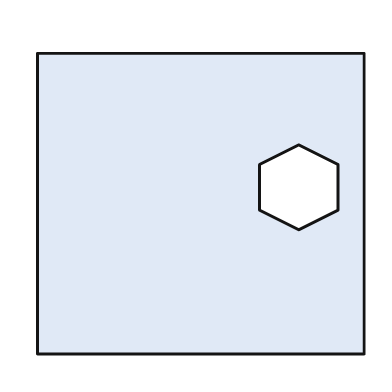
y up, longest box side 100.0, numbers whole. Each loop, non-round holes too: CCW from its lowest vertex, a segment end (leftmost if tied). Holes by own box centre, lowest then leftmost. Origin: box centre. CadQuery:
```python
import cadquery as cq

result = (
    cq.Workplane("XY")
    .moveTo(-50.0, -46.0)
    .lineTo(50.0, -46.0)
    .lineTo(50.0, 46.0)
    .lineTo(-50.0, 46.0)
    .close()
    .moveTo(30.0, -8.0)
    .lineTo(42.0, -2.0)
    .lineTo(42.0, 12.0)
    .lineTo(30.0, 18.0)
    .lineTo(18.0, 12.0)
    .lineTo(18.0, -2.0)
    .close()
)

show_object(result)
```